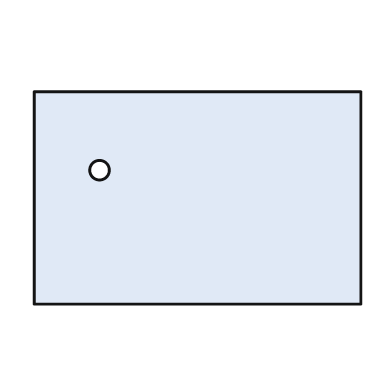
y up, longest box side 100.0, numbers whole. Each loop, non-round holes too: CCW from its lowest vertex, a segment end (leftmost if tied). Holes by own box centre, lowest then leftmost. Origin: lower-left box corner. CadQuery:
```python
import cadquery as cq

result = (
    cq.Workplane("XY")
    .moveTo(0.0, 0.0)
    .lineTo(100.0, 0.0)
    .lineTo(100.0, 65.0)
    .lineTo(0.0, 65.0)
    .close()
    .moveTo(20.0, 41.0)
    .circle(3.0)
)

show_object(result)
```